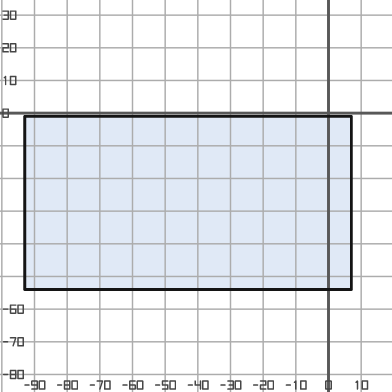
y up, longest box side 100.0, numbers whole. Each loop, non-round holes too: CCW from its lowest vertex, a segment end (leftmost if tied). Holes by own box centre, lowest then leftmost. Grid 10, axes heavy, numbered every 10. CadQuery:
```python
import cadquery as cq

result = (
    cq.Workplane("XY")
    .moveTo(-93.0, -54.0)
    .lineTo(7.0, -54.0)
    .lineTo(7.0, -1.0)
    .lineTo(-93.0, -1.0)
    .close()
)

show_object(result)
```